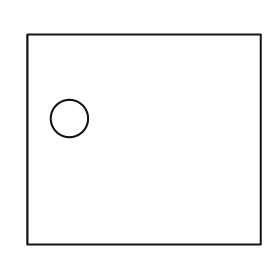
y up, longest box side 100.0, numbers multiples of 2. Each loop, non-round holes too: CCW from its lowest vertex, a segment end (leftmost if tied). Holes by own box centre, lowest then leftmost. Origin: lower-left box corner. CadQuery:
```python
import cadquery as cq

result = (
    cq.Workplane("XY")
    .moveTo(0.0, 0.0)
    .lineTo(100.0, 0.0)
    .lineTo(100.0, 90.0)
    .lineTo(0.0, 90.0)
    .close()
    .moveTo(18.0, 54.0)
    .circle(8.0)
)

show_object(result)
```